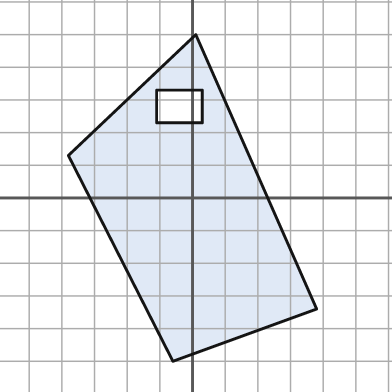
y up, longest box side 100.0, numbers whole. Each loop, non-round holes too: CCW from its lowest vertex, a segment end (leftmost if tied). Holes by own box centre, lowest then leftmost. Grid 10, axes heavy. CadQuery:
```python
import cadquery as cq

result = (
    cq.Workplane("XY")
    .moveTo(-6.0, -50.0)
    .lineTo(38.0, -34.0)
    .lineTo(1.0, 50.0)
    .lineTo(-38.0, 13.0)
    .close()
    .moveTo(-11.0, 23.0)
    .lineTo(3.0, 23.0)
    .lineTo(3.0, 33.0)
    .lineTo(-11.0, 33.0)
    .close()
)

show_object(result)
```